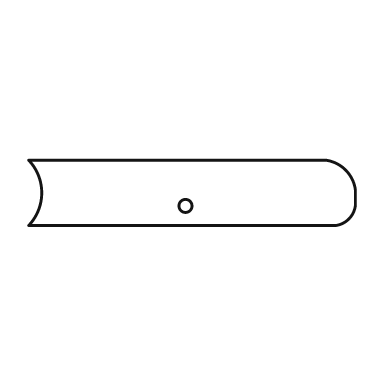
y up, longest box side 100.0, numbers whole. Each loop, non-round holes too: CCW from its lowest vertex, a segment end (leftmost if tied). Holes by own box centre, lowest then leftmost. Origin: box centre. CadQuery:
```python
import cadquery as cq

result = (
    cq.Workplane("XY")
    .moveTo(-50.0, -10.0)
    .lineTo(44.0, -10.0)
    .threePointArc((48.0, -8.0), (50.0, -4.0))
    .lineTo(50.0, 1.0)
    .threePointArc((47.0, 7.0), (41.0, 10.0))
    .lineTo(-50.0, 10.0)
    .threePointArc((-46.0, 0.0), (-50.0, -10.0))
    .close()
    .moveTo(-2.0, -4.0)
    .circle(2.0)
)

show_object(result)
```